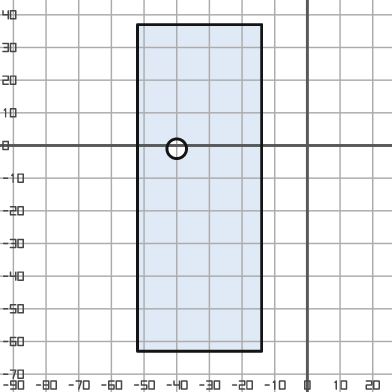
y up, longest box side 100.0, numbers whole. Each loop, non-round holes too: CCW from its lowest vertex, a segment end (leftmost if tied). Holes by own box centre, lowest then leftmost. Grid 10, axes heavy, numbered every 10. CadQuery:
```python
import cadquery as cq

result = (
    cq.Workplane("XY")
    .moveTo(-52.0, -63.0)
    .lineTo(-14.0, -63.0)
    .lineTo(-14.0, 37.0)
    .lineTo(-52.0, 37.0)
    .close()
    .moveTo(-40.0, -1.0)
    .circle(3.0)
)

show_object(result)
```